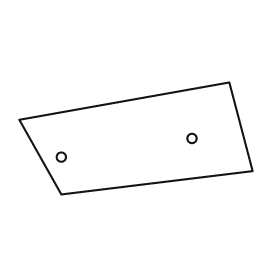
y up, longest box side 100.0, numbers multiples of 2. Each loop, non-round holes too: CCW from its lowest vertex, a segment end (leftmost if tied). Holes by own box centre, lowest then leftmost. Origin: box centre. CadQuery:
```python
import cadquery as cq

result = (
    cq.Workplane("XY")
    .moveTo(-32.0, -24.0)
    .lineTo(50.0, -14.0)
    .lineTo(40.0, 24.0)
    .lineTo(-50.0, 8.0)
    .close()
    .moveTo(-32.0, -8.0)
    .circle(2.0)
    .moveTo(24.0, 0.0)
    .circle(2.0)
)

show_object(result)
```